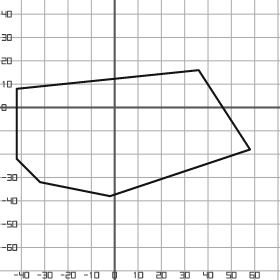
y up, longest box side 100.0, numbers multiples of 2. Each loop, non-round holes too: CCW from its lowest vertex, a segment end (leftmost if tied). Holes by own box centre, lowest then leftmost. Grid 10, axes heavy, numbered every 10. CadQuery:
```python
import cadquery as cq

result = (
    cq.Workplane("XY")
    .moveTo(-2.0, -38.0)
    .lineTo(58.0, -18.0)
    .lineTo(36.0, 16.0)
    .lineTo(-42.0, 8.0)
    .lineTo(-42.0, -22.0)
    .lineTo(-32.0, -32.0)
    .close()
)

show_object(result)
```